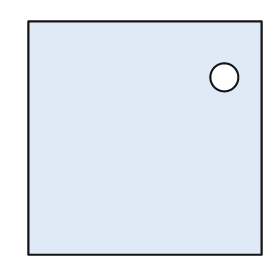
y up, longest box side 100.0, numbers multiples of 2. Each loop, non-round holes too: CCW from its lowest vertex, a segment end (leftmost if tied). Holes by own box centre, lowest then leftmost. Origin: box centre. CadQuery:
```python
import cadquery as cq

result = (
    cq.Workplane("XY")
    .moveTo(-50.0, -50.0)
    .lineTo(50.0, -50.0)
    .lineTo(50.0, 50.0)
    .lineTo(-50.0, 50.0)
    .close()
    .moveTo(34.0, 26.0)
    .circle(6.0)
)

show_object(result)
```